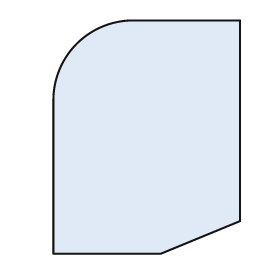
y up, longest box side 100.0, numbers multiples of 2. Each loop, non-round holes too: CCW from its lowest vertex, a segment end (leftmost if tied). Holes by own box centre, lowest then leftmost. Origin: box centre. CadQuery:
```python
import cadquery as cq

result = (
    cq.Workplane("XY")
    .moveTo(-40.0, -50.0)
    .lineTo(6.0, -50.0)
    .lineTo(40.0, -36.0)
    .lineTo(40.0, 50.0)
    .lineTo(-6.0, 50.0)
    .threePointArc((-30.0, 40.0), (-40.0, 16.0))
    .close()
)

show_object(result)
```